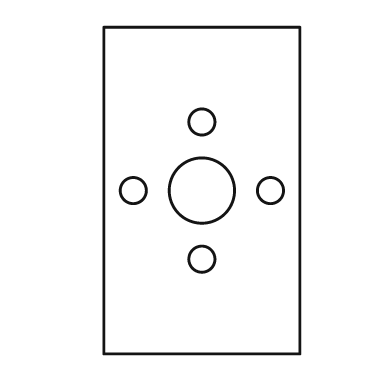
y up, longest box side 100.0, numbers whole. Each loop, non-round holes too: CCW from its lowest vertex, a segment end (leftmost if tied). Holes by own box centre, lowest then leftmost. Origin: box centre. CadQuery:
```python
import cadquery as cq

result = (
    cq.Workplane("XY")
    .moveTo(-30.0, -50.0)
    .lineTo(30.0, -50.0)
    .lineTo(30.0, 50.0)
    .lineTo(-30.0, 50.0)
    .close()
    .moveTo(0.0, -21.0)
    .circle(4.0)
    .moveTo(-21.0, 0.0)
    .circle(4.0)
    .moveTo(0.0, 0.0)
    .circle(10.0)
    .moveTo(21.0, 0.0)
    .circle(4.0)
    .moveTo(0.0, 21.0)
    .circle(4.0)
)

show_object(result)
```